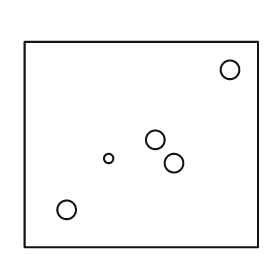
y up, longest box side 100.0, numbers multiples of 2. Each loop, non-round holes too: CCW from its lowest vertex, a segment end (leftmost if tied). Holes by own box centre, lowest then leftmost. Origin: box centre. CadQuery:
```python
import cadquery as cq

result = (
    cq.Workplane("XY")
    .moveTo(-50.0, -44.0)
    .lineTo(50.0, -44.0)
    .lineTo(50.0, 44.0)
    .lineTo(-50.0, 44.0)
    .close()
    .moveTo(-32.0, -28.0)
    .circle(4.0)
    .moveTo(14.0, -8.0)
    .circle(4.0)
    .moveTo(-14.0, -6.0)
    .circle(2.0)
    .moveTo(6.0, 2.0)
    .circle(4.0)
    .moveTo(38.0, 32.0)
    .circle(4.0)
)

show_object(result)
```